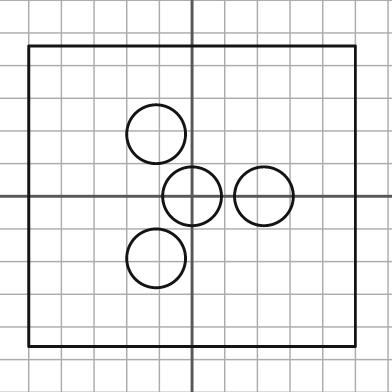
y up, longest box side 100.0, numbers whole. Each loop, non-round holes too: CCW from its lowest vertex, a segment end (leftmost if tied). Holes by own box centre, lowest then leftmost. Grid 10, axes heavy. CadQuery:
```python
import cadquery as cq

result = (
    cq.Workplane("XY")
    .moveTo(-50.0, -46.0)
    .lineTo(50.0, -46.0)
    .lineTo(50.0, 46.0)
    .lineTo(-50.0, 46.0)
    .close()
    .moveTo(-11.0, -19.0)
    .circle(9.0)
    .moveTo(0.0, 0.0)
    .circle(9.0)
    .moveTo(22.0, 0.0)
    .circle(9.0)
    .moveTo(-11.0, 19.0)
    .circle(9.0)
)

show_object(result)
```